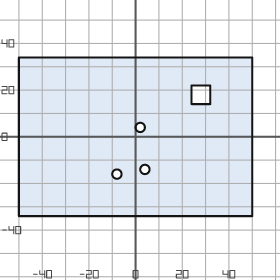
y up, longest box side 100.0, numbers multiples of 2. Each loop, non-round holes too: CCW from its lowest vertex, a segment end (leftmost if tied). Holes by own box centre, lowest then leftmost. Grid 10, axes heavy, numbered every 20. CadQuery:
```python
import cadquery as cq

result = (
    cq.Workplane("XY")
    .moveTo(-50.0, -34.0)
    .lineTo(50.0, -34.0)
    .lineTo(50.0, 34.0)
    .lineTo(-50.0, 34.0)
    .close()
    .moveTo(-8.0, -16.0)
    .circle(2.0)
    .moveTo(4.0, -14.0)
    .circle(2.0)
    .moveTo(2.0, 4.0)
    .circle(2.0)
    .moveTo(24.0, 14.0)
    .lineTo(32.0, 14.0)
    .lineTo(32.0, 22.0)
    .lineTo(24.0, 22.0)
    .close()
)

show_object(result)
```